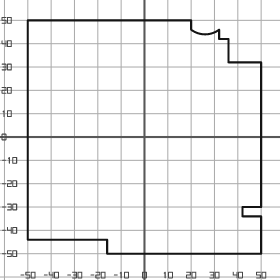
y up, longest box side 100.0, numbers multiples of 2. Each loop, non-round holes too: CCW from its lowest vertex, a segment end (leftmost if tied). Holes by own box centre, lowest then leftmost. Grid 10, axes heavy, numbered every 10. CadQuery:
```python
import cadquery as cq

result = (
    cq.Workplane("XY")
    .moveTo(-16.0, -50.0)
    .lineTo(50.0, -50.0)
    .lineTo(50.0, -34.0)
    .lineTo(42.0, -34.0)
    .lineTo(42.0, -30.0)
    .lineTo(50.0, -30.0)
    .lineTo(50.0, 32.0)
    .lineTo(36.0, 32.0)
    .lineTo(36.0, 42.0)
    .lineTo(32.0, 42.0)
    .lineTo(32.0, 46.0)
    .threePointArc((26.0, 44.0), (20.0, 46.0))
    .lineTo(20.0, 50.0)
    .lineTo(-50.0, 50.0)
    .lineTo(-50.0, -44.0)
    .lineTo(-16.0, -44.0)
    .close()
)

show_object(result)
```